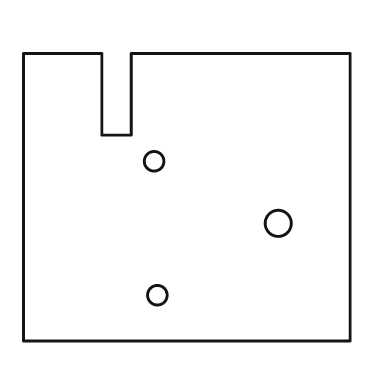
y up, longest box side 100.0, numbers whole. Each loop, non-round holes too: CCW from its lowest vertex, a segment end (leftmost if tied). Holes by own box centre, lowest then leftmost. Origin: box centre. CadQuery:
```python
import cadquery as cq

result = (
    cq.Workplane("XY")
    .moveTo(-50.0, -44.0)
    .lineTo(50.0, -44.0)
    .lineTo(50.0, 44.0)
    .lineTo(-17.0, 44.0)
    .lineTo(-17.0, 19.0)
    .lineTo(-26.0, 19.0)
    .lineTo(-26.0, 44.0)
    .lineTo(-50.0, 44.0)
    .close()
    .moveTo(-9.0, -30.0)
    .circle(3.0)
    .moveTo(28.0, -8.0)
    .circle(4.0)
    .moveTo(-10.0, 11.0)
    .circle(3.0)
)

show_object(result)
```